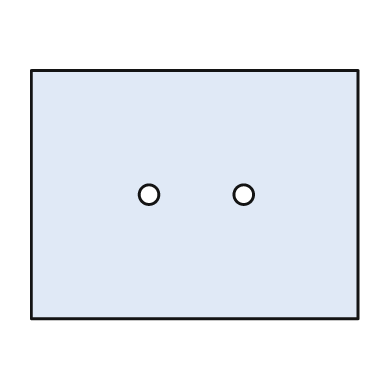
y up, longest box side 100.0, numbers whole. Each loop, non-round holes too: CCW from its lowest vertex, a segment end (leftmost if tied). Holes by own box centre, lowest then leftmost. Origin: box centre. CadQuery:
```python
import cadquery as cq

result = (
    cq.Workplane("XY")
    .moveTo(-50.0, -38.0)
    .lineTo(50.0, -38.0)
    .lineTo(50.0, 38.0)
    .lineTo(-50.0, 38.0)
    .close()
    .moveTo(-14.0, 0.0)
    .circle(3.0)
    .moveTo(15.0, 0.0)
    .circle(3.0)
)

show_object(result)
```